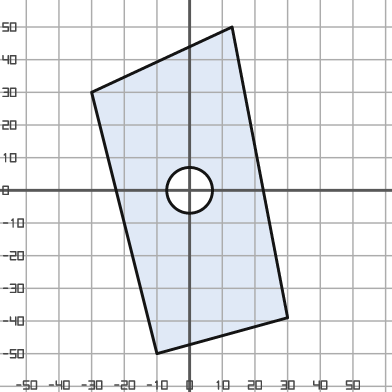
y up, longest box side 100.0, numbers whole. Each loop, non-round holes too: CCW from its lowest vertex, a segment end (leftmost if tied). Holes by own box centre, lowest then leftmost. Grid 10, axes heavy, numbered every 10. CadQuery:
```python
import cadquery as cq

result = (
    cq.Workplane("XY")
    .moveTo(-10.0, -50.0)
    .lineTo(30.0, -39.0)
    .lineTo(13.0, 50.0)
    .lineTo(-30.0, 30.0)
    .close()
    .moveTo(0.0, 0.0)
    .circle(7.0)
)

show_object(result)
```